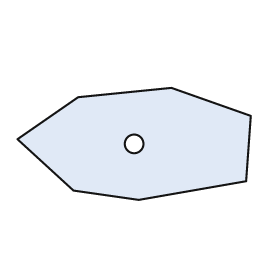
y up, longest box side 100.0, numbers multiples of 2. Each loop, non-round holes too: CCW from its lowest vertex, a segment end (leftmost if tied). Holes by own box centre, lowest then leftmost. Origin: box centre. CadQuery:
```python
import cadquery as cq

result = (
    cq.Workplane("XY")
    .moveTo(2.0, -24.0)
    .lineTo(48.0, -16.0)
    .lineTo(50.0, 12.0)
    .lineTo(16.0, 24.0)
    .lineTo(-24.0, 20.0)
    .lineTo(-50.0, 2.0)
    .lineTo(-26.0, -20.0)
    .close()
    .moveTo(0.0, 0.0)
    .circle(4.0)
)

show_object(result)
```